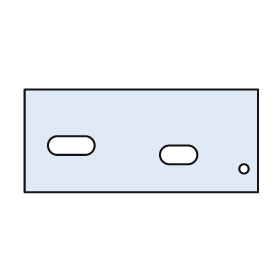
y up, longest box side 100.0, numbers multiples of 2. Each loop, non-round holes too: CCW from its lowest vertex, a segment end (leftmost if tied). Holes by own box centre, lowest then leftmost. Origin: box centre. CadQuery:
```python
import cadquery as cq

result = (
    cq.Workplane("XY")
    .moveTo(-50.0, -22.0)
    .lineTo(50.0, -22.0)
    .lineTo(50.0, 22.0)
    .lineTo(-50.0, 22.0)
    .close()
    .moveTo(44.0, -12.0)
    .circle(2.0)
    .moveTo(12.0, -10.0)
    .lineTo(20.0, -10.0)
    .threePointArc((24.0, -6.0), (20.0, -2.0))
    .lineTo(12.0, -2.0)
    .threePointArc((8.0, -6.0), (12.0, -10.0))
    .close()
    .moveTo(-36.0, -6.0)
    .lineTo(-24.0, -6.0)
    .threePointArc((-20.0, -2.0), (-24.0, 2.0))
    .lineTo(-36.0, 2.0)
    .threePointArc((-40.0, -2.0), (-36.0, -6.0))
    .close()
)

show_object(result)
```